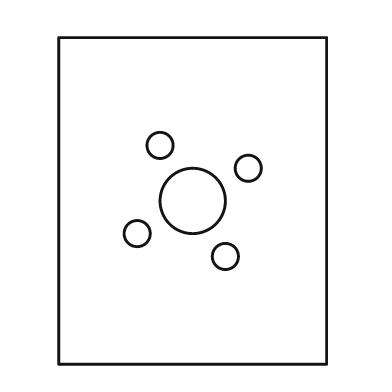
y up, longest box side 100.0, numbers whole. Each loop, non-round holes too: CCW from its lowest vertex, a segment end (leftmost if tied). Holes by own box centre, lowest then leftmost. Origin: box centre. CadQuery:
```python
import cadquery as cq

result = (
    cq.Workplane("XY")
    .moveTo(-41.0, -50.0)
    .lineTo(41.0, -50.0)
    .lineTo(41.0, 50.0)
    .lineTo(-41.0, 50.0)
    .close()
    .moveTo(10.0, -17.0)
    .circle(4.0)
    .moveTo(-17.0, -10.0)
    .circle(4.0)
    .moveTo(0.0, 0.0)
    .circle(10.0)
    .moveTo(17.0, 10.0)
    .circle(4.0)
    .moveTo(-10.0, 17.0)
    .circle(4.0)
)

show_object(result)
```